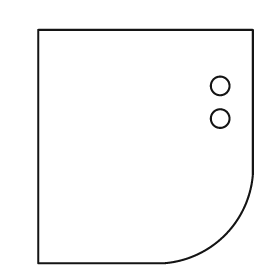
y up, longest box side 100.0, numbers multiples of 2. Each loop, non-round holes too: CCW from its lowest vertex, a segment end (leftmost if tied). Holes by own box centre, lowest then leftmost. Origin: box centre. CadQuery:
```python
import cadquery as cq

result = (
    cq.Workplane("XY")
    .moveTo(-46.0, -50.0)
    .lineTo(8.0, -50.0)
    .threePointArc((34.0, -38.0), (46.0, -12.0))
    .lineTo(46.0, 50.0)
    .lineTo(-46.0, 50.0)
    .close()
    .moveTo(32.0, 12.0)
    .circle(4.0)
    .moveTo(32.0, 26.0)
    .circle(4.0)
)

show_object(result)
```